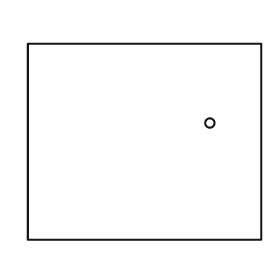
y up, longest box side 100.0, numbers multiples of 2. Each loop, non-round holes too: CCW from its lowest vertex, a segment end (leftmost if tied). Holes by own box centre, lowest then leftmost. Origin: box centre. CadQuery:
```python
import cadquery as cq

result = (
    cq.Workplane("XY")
    .moveTo(-50.0, -42.0)
    .lineTo(50.0, -42.0)
    .lineTo(50.0, 42.0)
    .lineTo(-50.0, 42.0)
    .close()
    .moveTo(28.0, 8.0)
    .circle(2.0)
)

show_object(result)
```